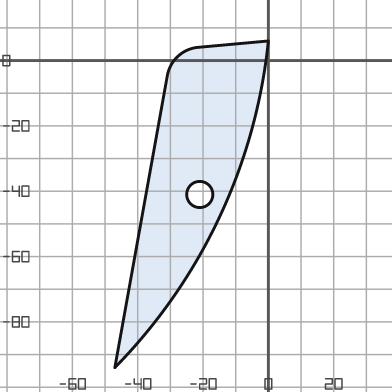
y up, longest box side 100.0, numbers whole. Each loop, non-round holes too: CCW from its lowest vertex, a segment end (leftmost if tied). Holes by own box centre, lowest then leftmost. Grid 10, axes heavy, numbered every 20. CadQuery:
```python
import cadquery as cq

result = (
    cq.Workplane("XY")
    .moveTo(-47.0, -94.0)
    .threePointArc((-15.0, -48.0), (0.0, 6.0))
    .lineTo(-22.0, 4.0)
    .threePointArc((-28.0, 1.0), (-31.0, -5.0))
    .close()
    .moveTo(-21.0, -41.0)
    .circle(4.0)
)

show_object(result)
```